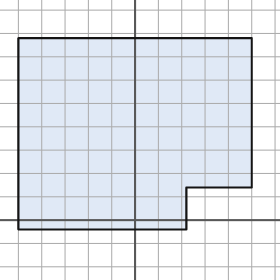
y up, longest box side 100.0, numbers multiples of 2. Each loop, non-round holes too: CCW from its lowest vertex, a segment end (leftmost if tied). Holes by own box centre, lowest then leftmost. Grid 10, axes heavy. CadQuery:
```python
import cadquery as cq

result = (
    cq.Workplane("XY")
    .moveTo(-50.0, -4.0)
    .lineTo(22.0, -4.0)
    .lineTo(22.0, 14.0)
    .lineTo(50.0, 14.0)
    .lineTo(50.0, 78.0)
    .lineTo(-50.0, 78.0)
    .close()
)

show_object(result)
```